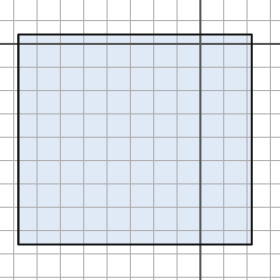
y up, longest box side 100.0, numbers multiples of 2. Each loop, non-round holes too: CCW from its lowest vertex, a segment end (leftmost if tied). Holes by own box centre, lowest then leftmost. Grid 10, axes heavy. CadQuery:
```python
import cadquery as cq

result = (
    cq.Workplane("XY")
    .moveTo(-78.0, -86.0)
    .lineTo(22.0, -86.0)
    .lineTo(22.0, 4.0)
    .lineTo(-78.0, 4.0)
    .close()
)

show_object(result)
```